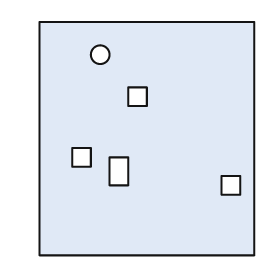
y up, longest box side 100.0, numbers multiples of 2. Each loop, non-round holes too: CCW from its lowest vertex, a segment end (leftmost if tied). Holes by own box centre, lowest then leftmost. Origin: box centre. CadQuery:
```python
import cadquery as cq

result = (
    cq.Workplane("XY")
    .moveTo(-46.0, -50.0)
    .lineTo(46.0, -50.0)
    .lineTo(46.0, 50.0)
    .lineTo(-46.0, 50.0)
    .close()
    .moveTo(32.0, -24.0)
    .lineTo(40.0, -24.0)
    .lineTo(40.0, -16.0)
    .lineTo(32.0, -16.0)
    .close()
    .moveTo(-16.0, -20.0)
    .lineTo(-8.0, -20.0)
    .lineTo(-8.0, -8.0)
    .lineTo(-16.0, -8.0)
    .close()
    .moveTo(-32.0, -12.0)
    .lineTo(-24.0, -12.0)
    .lineTo(-24.0, -4.0)
    .lineTo(-32.0, -4.0)
    .close()
    .moveTo(-8.0, 14.0)
    .lineTo(0.0, 14.0)
    .lineTo(0.0, 22.0)
    .lineTo(-8.0, 22.0)
    .close()
    .moveTo(-20.0, 36.0)
    .circle(4.0)
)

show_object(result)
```